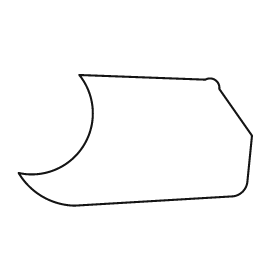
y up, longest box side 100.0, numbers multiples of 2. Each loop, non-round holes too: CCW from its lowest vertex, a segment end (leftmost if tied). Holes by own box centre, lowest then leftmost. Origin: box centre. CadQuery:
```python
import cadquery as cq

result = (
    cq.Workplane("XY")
    .moveTo(-26.0, -28.0)
    .lineTo(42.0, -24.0)
    .threePointArc((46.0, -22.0), (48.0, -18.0))
    .lineTo(50.0, 2.0)
    .lineTo(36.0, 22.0)
    .threePointArc((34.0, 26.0), (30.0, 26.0))
    .lineTo(-24.0, 28.0)
    .threePointArc((-22.0, -2.0), (-50.0, -14.0))
    .threePointArc((-40.0, -24.0), (-26.0, -28.0))
    .close()
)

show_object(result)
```